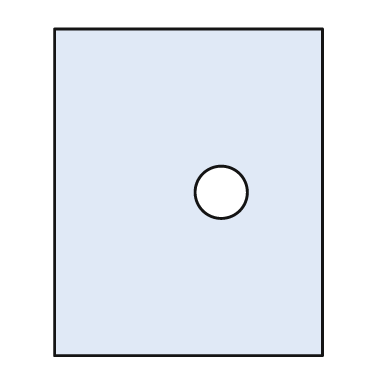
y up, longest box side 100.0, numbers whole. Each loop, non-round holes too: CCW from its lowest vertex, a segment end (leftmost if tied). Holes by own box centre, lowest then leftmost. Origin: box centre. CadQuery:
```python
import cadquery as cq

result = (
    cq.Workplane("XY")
    .moveTo(-41.0, -50.0)
    .lineTo(41.0, -50.0)
    .lineTo(41.0, 50.0)
    .lineTo(-41.0, 50.0)
    .close()
    .moveTo(10.0, 0.0)
    .circle(8.0)
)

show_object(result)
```